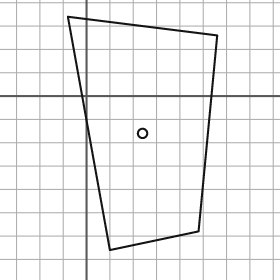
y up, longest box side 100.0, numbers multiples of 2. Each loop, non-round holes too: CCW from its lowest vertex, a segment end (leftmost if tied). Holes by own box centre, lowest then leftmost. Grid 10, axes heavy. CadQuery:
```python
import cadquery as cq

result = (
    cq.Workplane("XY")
    .moveTo(10.0, -66.0)
    .lineTo(48.0, -58.0)
    .lineTo(56.0, 26.0)
    .lineTo(-8.0, 34.0)
    .close()
    .moveTo(24.0, -16.0)
    .circle(2.0)
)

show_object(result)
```